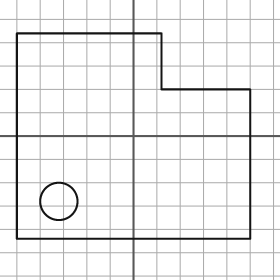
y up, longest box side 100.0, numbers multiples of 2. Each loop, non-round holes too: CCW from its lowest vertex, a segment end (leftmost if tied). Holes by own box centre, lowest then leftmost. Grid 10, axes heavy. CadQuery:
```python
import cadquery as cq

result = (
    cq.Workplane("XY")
    .moveTo(-50.0, -44.0)
    .lineTo(50.0, -44.0)
    .lineTo(50.0, 20.0)
    .lineTo(12.0, 20.0)
    .lineTo(12.0, 44.0)
    .lineTo(-50.0, 44.0)
    .close()
    .moveTo(-32.0, -28.0)
    .circle(8.0)
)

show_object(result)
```